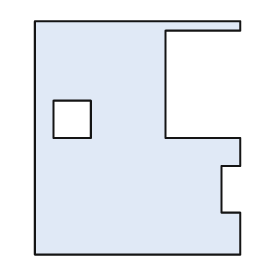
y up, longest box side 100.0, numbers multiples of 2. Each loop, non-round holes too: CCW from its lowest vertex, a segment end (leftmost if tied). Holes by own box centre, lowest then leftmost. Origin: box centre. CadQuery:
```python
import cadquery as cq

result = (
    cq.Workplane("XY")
    .moveTo(-44.0, -50.0)
    .lineTo(44.0, -50.0)
    .lineTo(44.0, -32.0)
    .lineTo(36.0, -32.0)
    .lineTo(36.0, -12.0)
    .lineTo(44.0, -12.0)
    .lineTo(44.0, 0.0)
    .lineTo(12.0, 0.0)
    .lineTo(12.0, 46.0)
    .lineTo(44.0, 46.0)
    .lineTo(44.0, 50.0)
    .lineTo(-44.0, 50.0)
    .close()
    .moveTo(-36.0, 0.0)
    .lineTo(-20.0, 0.0)
    .lineTo(-20.0, 16.0)
    .lineTo(-36.0, 16.0)
    .close()
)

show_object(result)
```